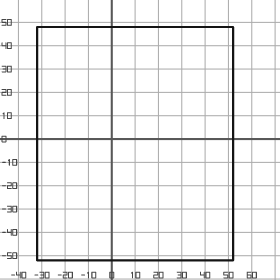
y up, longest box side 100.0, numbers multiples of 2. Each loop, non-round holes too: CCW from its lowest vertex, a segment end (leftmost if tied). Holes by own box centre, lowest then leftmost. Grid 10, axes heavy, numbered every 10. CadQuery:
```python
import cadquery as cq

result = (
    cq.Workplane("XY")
    .moveTo(-32.0, -52.0)
    .lineTo(52.0, -52.0)
    .lineTo(52.0, 48.0)
    .lineTo(-32.0, 48.0)
    .close()
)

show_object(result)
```